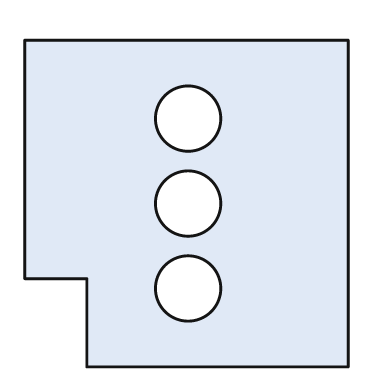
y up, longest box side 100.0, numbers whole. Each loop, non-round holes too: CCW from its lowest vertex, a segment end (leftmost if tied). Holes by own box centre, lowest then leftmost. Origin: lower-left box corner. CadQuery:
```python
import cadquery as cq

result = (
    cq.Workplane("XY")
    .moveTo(19.0, 0.0)
    .lineTo(99.0, 0.0)
    .lineTo(99.0, 100.0)
    .lineTo(0.0, 100.0)
    .lineTo(0.0, 27.0)
    .lineTo(19.0, 27.0)
    .close()
    .moveTo(50.0, 24.0)
    .circle(10.0)
    .moveTo(50.0, 50.0)
    .circle(10.0)
    .moveTo(50.0, 76.0)
    .circle(10.0)
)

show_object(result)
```